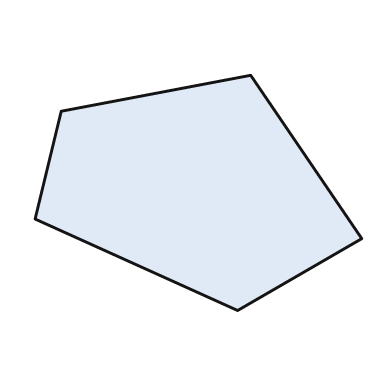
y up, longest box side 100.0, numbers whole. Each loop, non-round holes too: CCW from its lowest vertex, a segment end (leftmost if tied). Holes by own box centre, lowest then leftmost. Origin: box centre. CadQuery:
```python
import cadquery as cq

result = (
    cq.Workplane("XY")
    .moveTo(12.0, -36.0)
    .lineTo(50.0, -14.0)
    .lineTo(16.0, 36.0)
    .lineTo(-42.0, 25.0)
    .lineTo(-50.0, -8.0)
    .close()
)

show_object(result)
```